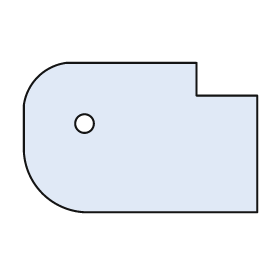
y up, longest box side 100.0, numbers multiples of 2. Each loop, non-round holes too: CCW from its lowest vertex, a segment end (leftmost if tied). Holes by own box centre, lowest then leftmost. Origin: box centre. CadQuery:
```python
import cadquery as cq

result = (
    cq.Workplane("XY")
    .moveTo(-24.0, -32.0)
    .lineTo(50.0, -32.0)
    .lineTo(50.0, 18.0)
    .lineTo(24.0, 18.0)
    .lineTo(24.0, 32.0)
    .lineTo(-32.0, 32.0)
    .threePointArc((-44.0, 26.0), (-50.0, 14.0))
    .lineTo(-50.0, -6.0)
    .threePointArc((-42.0, -24.0), (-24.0, -32.0))
    .close()
    .moveTo(-24.0, 6.0)
    .circle(4.0)
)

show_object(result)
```